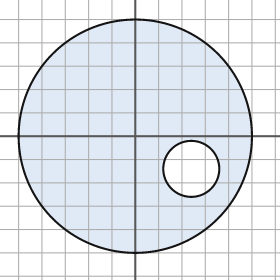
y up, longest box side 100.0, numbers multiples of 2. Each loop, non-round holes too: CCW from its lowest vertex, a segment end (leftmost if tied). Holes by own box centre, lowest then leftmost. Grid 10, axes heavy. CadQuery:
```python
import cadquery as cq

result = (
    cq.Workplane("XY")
    .moveTo(0.0, 0.0)
    .circle(50.0)
    .moveTo(24.0, -14.0)
    .circle(12.0)
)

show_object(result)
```